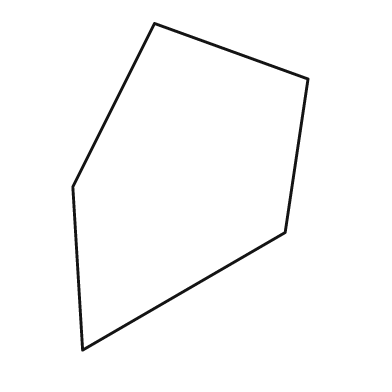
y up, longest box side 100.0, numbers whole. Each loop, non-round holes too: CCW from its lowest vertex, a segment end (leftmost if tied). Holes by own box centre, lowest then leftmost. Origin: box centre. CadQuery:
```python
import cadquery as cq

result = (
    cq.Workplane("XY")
    .moveTo(-33.0, -50.0)
    .lineTo(29.0, -14.0)
    .lineTo(36.0, 33.0)
    .lineTo(-11.0, 50.0)
    .lineTo(-36.0, 0.0)
    .close()
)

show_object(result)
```